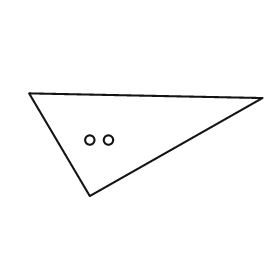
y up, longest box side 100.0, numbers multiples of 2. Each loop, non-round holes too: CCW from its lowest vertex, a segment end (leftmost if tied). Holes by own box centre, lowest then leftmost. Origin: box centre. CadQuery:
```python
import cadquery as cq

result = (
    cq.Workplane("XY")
    .moveTo(-24.0, -22.0)
    .lineTo(50.0, 20.0)
    .lineTo(-50.0, 22.0)
    .close()
    .moveTo(-24.0, 2.0)
    .circle(2.0)
    .moveTo(-16.0, 2.0)
    .circle(2.0)
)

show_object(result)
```